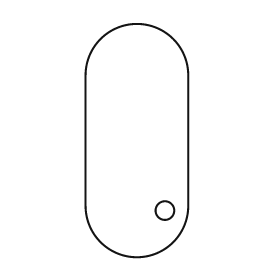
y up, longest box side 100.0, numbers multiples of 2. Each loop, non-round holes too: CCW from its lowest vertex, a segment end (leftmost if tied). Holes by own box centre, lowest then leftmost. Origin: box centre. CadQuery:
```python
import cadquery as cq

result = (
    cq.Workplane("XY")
    .moveTo(-22.0, -28.0)
    .threePointArc((0.0, -50.0), (22.0, -28.0))
    .lineTo(22.0, 28.0)
    .threePointArc((0.0, 50.0), (-22.0, 28.0))
    .close()
    .moveTo(12.0, -30.0)
    .circle(4.0)
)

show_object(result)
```